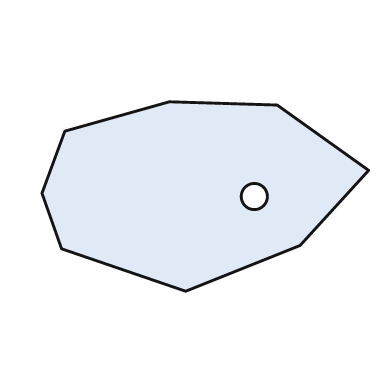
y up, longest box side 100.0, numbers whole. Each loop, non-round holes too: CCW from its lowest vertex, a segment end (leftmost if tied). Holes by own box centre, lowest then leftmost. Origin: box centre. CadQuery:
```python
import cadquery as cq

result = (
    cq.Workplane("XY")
    .moveTo(-6.0, -29.0)
    .lineTo(29.0, -15.0)
    .lineTo(50.0, 8.0)
    .lineTo(22.0, 28.0)
    .lineTo(-11.0, 29.0)
    .lineTo(-43.0, 20.0)
    .lineTo(-50.0, 1.0)
    .lineTo(-44.0, -16.0)
    .close()
    .moveTo(15.0, 0.0)
    .circle(4.0)
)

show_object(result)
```